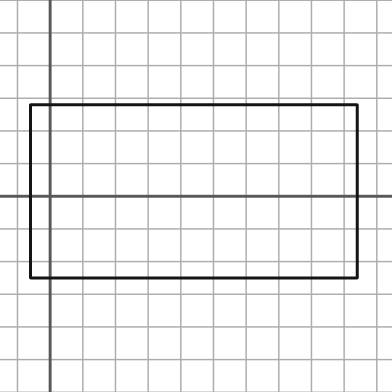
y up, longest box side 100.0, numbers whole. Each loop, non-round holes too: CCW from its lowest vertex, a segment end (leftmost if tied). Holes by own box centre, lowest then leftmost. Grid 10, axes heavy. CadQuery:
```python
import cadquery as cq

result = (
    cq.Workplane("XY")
    .moveTo(-6.0, -25.0)
    .lineTo(94.0, -25.0)
    .lineTo(94.0, 28.0)
    .lineTo(-6.0, 28.0)
    .close()
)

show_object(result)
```